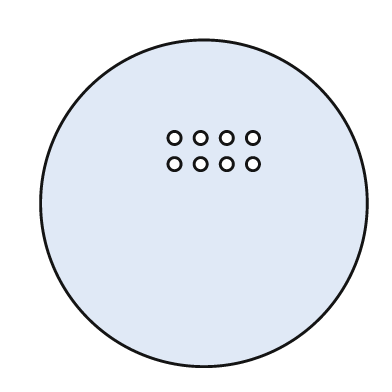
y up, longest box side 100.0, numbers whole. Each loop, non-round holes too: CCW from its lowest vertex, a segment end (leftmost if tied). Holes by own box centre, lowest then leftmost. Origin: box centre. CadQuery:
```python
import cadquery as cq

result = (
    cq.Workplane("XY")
    .moveTo(0.0, 0.0)
    .circle(50.0)
    .moveTo(-9.0, 12.0)
    .circle(2.0)
    .moveTo(-1.0, 12.0)
    .circle(2.0)
    .moveTo(7.0, 12.0)
    .circle(2.0)
    .moveTo(15.0, 12.0)
    .circle(2.0)
    .moveTo(-9.0, 20.0)
    .circle(2.0)
    .moveTo(-1.0, 20.0)
    .circle(2.0)
    .moveTo(7.0, 20.0)
    .circle(2.0)
    .moveTo(15.0, 20.0)
    .circle(2.0)
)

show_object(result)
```